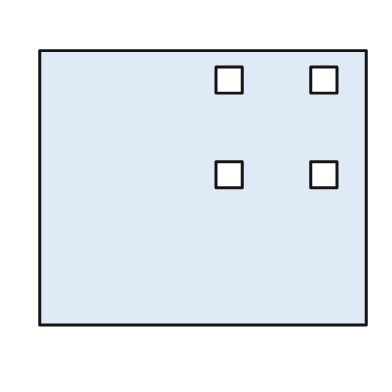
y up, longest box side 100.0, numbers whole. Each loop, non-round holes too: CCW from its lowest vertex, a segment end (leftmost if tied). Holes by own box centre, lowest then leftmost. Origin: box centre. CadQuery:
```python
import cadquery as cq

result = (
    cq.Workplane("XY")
    .moveTo(-50.0, -42.0)
    .lineTo(50.0, -42.0)
    .lineTo(50.0, 42.0)
    .lineTo(-50.0, 42.0)
    .close()
    .moveTo(4.0, 0.0)
    .lineTo(12.0, 0.0)
    .lineTo(12.0, 8.0)
    .lineTo(4.0, 8.0)
    .close()
    .moveTo(33.0, 0.0)
    .lineTo(41.0, 0.0)
    .lineTo(41.0, 8.0)
    .lineTo(33.0, 8.0)
    .close()
    .moveTo(4.0, 29.0)
    .lineTo(12.0, 29.0)
    .lineTo(12.0, 37.0)
    .lineTo(4.0, 37.0)
    .close()
    .moveTo(33.0, 29.0)
    .lineTo(41.0, 29.0)
    .lineTo(41.0, 37.0)
    .lineTo(33.0, 37.0)
    .close()
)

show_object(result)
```